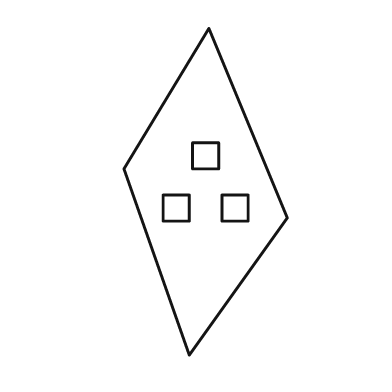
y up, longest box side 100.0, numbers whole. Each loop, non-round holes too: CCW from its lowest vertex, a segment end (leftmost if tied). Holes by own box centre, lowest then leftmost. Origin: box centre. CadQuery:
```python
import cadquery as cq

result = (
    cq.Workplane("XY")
    .moveTo(-5.0, -50.0)
    .lineTo(25.0, -8.0)
    .lineTo(1.0, 50.0)
    .lineTo(-25.0, 7.0)
    .close()
    .moveTo(-13.0, -9.0)
    .lineTo(-5.0, -9.0)
    .lineTo(-5.0, -1.0)
    .lineTo(-13.0, -1.0)
    .close()
    .moveTo(5.0, -9.0)
    .lineTo(13.0, -9.0)
    .lineTo(13.0, -1.0)
    .lineTo(5.0, -1.0)
    .close()
    .moveTo(-4.0, 7.0)
    .lineTo(4.0, 7.0)
    .lineTo(4.0, 15.0)
    .lineTo(-4.0, 15.0)
    .close()
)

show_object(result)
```